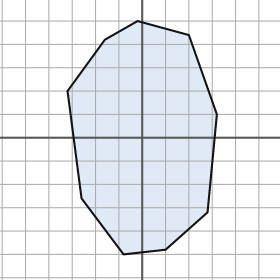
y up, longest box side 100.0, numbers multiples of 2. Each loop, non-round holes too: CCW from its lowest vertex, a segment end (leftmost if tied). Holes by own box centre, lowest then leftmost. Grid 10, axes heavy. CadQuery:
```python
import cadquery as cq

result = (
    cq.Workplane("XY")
    .moveTo(-8.0, -50.0)
    .lineTo(10.0, -48.0)
    .lineTo(28.0, -32.0)
    .lineTo(32.0, 10.0)
    .lineTo(20.0, 44.0)
    .lineTo(-2.0, 50.0)
    .lineTo(-16.0, 42.0)
    .lineTo(-32.0, 20.0)
    .lineTo(-26.0, -26.0)
    .close()
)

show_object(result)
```